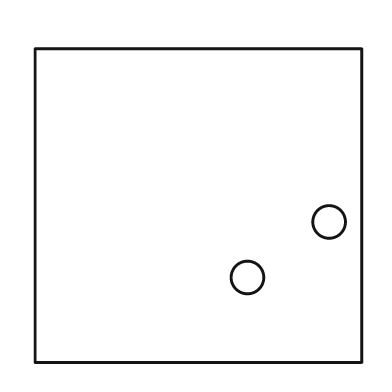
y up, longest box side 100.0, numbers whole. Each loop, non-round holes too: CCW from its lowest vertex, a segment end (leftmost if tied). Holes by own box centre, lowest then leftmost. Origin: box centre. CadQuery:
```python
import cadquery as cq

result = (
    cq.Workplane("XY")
    .moveTo(-50.0, -48.0)
    .lineTo(50.0, -48.0)
    .lineTo(50.0, 48.0)
    .lineTo(-50.0, 48.0)
    .close()
    .moveTo(15.0, -22.0)
    .circle(5.0)
    .moveTo(40.0, -5.0)
    .circle(5.0)
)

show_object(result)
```